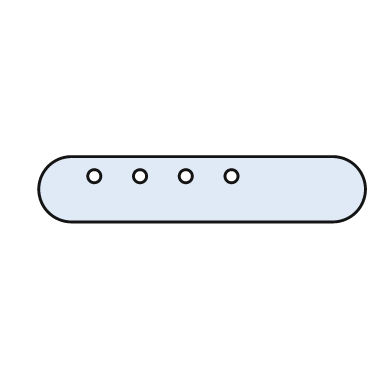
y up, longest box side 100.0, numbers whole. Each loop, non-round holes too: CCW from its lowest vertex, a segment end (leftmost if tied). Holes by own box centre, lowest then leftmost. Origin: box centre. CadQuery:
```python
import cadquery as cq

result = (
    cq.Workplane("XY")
    .moveTo(-40.0, -10.0)
    .lineTo(40.0, -10.0)
    .threePointArc((50.0, 0.0), (40.0, 10.0))
    .lineTo(-40.0, 10.0)
    .threePointArc((-50.0, 0.0), (-40.0, -10.0))
    .close()
    .moveTo(-33.0, 4.0)
    .circle(2.0)
    .moveTo(-19.0, 4.0)
    .circle(2.0)
    .moveTo(-5.0, 4.0)
    .circle(2.0)
    .moveTo(9.0, 4.0)
    .circle(2.0)
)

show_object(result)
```